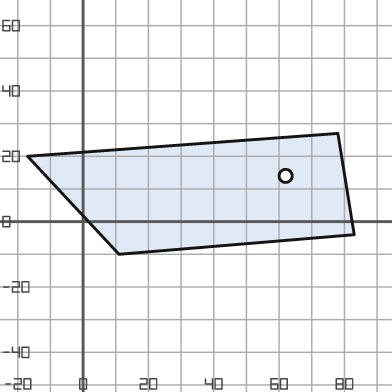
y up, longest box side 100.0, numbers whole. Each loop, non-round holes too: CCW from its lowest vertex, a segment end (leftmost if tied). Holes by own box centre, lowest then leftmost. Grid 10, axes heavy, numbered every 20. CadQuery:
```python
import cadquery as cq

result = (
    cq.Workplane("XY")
    .moveTo(11.0, -10.0)
    .lineTo(83.0, -4.0)
    .lineTo(78.0, 27.0)
    .lineTo(-17.0, 20.0)
    .close()
    .moveTo(62.0, 14.0)
    .circle(2.0)
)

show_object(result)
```